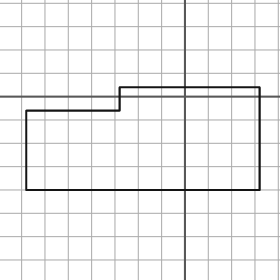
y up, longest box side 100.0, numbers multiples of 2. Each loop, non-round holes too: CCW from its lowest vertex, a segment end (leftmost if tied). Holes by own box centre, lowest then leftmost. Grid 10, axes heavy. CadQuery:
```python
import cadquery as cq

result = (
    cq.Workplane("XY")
    .moveTo(-68.0, -40.0)
    .lineTo(32.0, -40.0)
    .lineTo(32.0, 4.0)
    .lineTo(-28.0, 4.0)
    .lineTo(-28.0, -6.0)
    .lineTo(-68.0, -6.0)
    .close()
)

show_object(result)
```